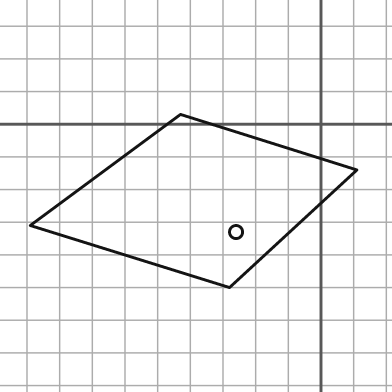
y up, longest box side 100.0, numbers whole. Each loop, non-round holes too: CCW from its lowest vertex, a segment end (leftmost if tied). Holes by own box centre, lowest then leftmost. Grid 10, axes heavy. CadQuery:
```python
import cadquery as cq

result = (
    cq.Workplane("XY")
    .moveTo(-28.0, -50.0)
    .lineTo(11.0, -14.0)
    .lineTo(-43.0, 3.0)
    .lineTo(-89.0, -31.0)
    .close()
    .moveTo(-26.0, -33.0)
    .circle(2.0)
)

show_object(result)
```